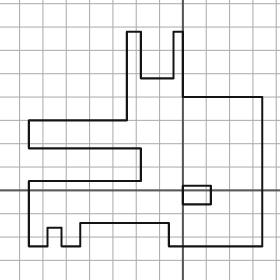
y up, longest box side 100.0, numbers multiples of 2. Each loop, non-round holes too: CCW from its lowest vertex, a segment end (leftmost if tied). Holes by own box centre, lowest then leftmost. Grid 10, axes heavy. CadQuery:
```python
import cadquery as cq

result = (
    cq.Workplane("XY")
    .moveTo(-66.0, -24.0)
    .lineTo(-58.0, -24.0)
    .lineTo(-58.0, -16.0)
    .lineTo(-52.0, -16.0)
    .lineTo(-52.0, -24.0)
    .lineTo(-44.0, -24.0)
    .lineTo(-44.0, -14.0)
    .lineTo(-6.0, -14.0)
    .lineTo(-6.0, -24.0)
    .lineTo(34.0, -24.0)
    .lineTo(34.0, 40.0)
    .lineTo(0.0, 40.0)
    .lineTo(0.0, 68.0)
    .lineTo(-4.0, 68.0)
    .lineTo(-4.0, 48.0)
    .lineTo(-18.0, 48.0)
    .lineTo(-18.0, 68.0)
    .lineTo(-24.0, 68.0)
    .lineTo(-24.0, 30.0)
    .lineTo(-66.0, 30.0)
    .lineTo(-66.0, 18.0)
    .lineTo(-18.0, 18.0)
    .lineTo(-18.0, 4.0)
    .lineTo(-66.0, 4.0)
    .close()
    .moveTo(0.0, -6.0)
    .lineTo(12.0, -6.0)
    .lineTo(12.0, 2.0)
    .lineTo(0.0, 2.0)
    .close()
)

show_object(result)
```